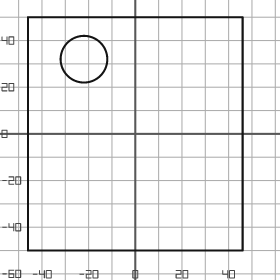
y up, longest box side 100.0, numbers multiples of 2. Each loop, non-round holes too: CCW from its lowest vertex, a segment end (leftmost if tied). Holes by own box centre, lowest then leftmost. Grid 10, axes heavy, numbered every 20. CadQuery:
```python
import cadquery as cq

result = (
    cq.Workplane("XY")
    .moveTo(-46.0, -50.0)
    .lineTo(46.0, -50.0)
    .lineTo(46.0, 50.0)
    .lineTo(-46.0, 50.0)
    .close()
    .moveTo(-22.0, 32.0)
    .circle(10.0)
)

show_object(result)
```